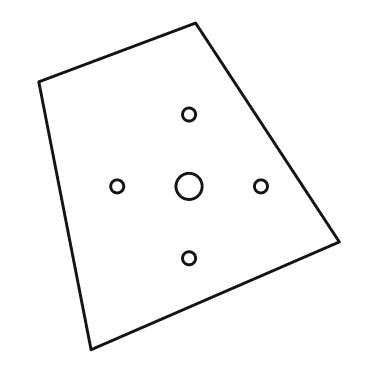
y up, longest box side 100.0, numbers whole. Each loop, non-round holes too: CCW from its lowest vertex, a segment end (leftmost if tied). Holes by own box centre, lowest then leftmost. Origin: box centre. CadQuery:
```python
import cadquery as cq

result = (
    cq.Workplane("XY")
    .moveTo(-30.0, -50.0)
    .lineTo(46.0, -17.0)
    .lineTo(2.0, 50.0)
    .lineTo(-46.0, 32.0)
    .close()
    .moveTo(0.0, -22.0)
    .circle(2.0)
    .moveTo(-22.0, 0.0)
    .circle(2.0)
    .moveTo(0.0, 0.0)
    .circle(4.0)
    .moveTo(22.0, 0.0)
    .circle(2.0)
    .moveTo(0.0, 22.0)
    .circle(2.0)
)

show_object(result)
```